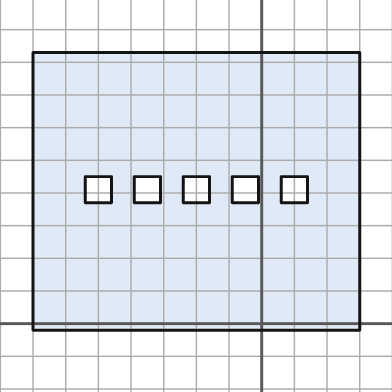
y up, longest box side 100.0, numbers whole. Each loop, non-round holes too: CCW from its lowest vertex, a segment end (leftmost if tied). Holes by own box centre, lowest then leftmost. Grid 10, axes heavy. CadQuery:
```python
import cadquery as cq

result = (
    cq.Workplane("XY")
    .moveTo(-70.0, -2.0)
    .lineTo(30.0, -2.0)
    .lineTo(30.0, 83.0)
    .lineTo(-70.0, 83.0)
    .close()
    .moveTo(-54.0, 37.0)
    .lineTo(-46.0, 37.0)
    .lineTo(-46.0, 45.0)
    .lineTo(-54.0, 45.0)
    .close()
    .moveTo(-39.0, 37.0)
    .lineTo(-31.0, 37.0)
    .lineTo(-31.0, 45.0)
    .lineTo(-39.0, 45.0)
    .close()
    .moveTo(-24.0, 37.0)
    .lineTo(-16.0, 37.0)
    .lineTo(-16.0, 45.0)
    .lineTo(-24.0, 45.0)
    .close()
    .moveTo(-9.0, 37.0)
    .lineTo(-1.0, 37.0)
    .lineTo(-1.0, 45.0)
    .lineTo(-9.0, 45.0)
    .close()
    .moveTo(6.0, 37.0)
    .lineTo(14.0, 37.0)
    .lineTo(14.0, 45.0)
    .lineTo(6.0, 45.0)
    .close()
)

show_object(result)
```